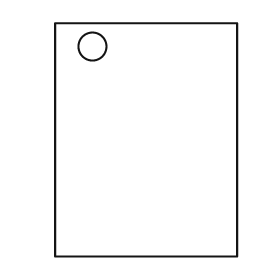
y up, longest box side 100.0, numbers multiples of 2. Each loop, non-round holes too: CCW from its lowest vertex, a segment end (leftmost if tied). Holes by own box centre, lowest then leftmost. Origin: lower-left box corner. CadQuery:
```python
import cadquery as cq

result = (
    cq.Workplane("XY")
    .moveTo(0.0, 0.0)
    .lineTo(78.0, 0.0)
    .lineTo(78.0, 100.0)
    .lineTo(0.0, 100.0)
    .close()
    .moveTo(16.0, 90.0)
    .circle(6.0)
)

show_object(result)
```